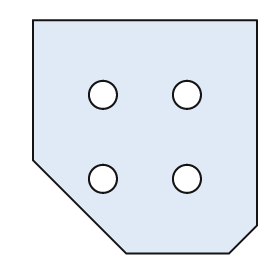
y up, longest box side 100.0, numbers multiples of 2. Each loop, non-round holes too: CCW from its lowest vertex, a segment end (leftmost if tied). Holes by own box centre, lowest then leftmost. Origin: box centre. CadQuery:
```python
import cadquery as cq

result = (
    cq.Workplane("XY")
    .moveTo(-8.0, -50.0)
    .lineTo(36.0, -50.0)
    .lineTo(48.0, -38.0)
    .lineTo(48.0, 50.0)
    .lineTo(-48.0, 50.0)
    .lineTo(-48.0, -10.0)
    .close()
    .moveTo(-18.0, -18.0)
    .circle(6.0)
    .moveTo(18.0, -18.0)
    .circle(6.0)
    .moveTo(-18.0, 18.0)
    .circle(6.0)
    .moveTo(18.0, 18.0)
    .circle(6.0)
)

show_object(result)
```